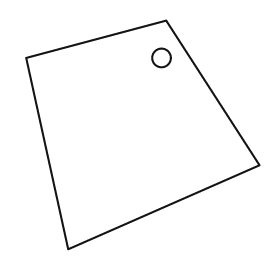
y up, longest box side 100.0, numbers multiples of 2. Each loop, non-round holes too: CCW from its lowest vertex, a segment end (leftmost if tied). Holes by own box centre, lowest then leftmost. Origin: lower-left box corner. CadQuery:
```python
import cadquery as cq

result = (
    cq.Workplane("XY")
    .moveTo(18.0, 0.0)
    .lineTo(100.0, 36.0)
    .lineTo(60.0, 98.0)
    .lineTo(0.0, 82.0)
    .close()
    .moveTo(58.0, 82.0)
    .circle(4.0)
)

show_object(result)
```